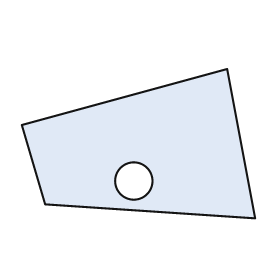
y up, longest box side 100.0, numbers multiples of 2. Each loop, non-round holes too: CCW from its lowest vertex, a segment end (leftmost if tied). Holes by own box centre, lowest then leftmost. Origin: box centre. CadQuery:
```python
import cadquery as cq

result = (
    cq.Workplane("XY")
    .moveTo(50.0, -32.0)
    .lineTo(38.0, 32.0)
    .lineTo(-50.0, 8.0)
    .lineTo(-40.0, -26.0)
    .close()
    .moveTo(-2.0, -16.0)
    .circle(8.0)
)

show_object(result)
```